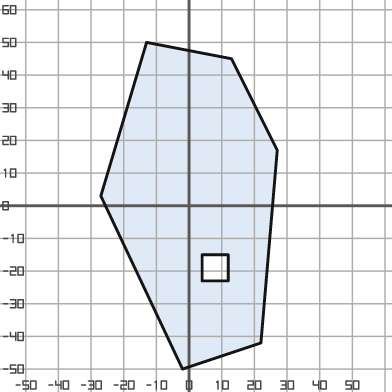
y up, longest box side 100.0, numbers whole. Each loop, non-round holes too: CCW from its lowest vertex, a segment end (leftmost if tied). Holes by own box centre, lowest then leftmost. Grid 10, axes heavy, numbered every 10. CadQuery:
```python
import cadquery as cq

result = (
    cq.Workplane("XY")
    .moveTo(-2.0, -50.0)
    .lineTo(22.0, -42.0)
    .lineTo(27.0, 17.0)
    .lineTo(13.0, 45.0)
    .lineTo(-13.0, 50.0)
    .lineTo(-27.0, 3.0)
    .close()
    .moveTo(4.0, -23.0)
    .lineTo(12.0, -23.0)
    .lineTo(12.0, -15.0)
    .lineTo(4.0, -15.0)
    .close()
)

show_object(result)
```